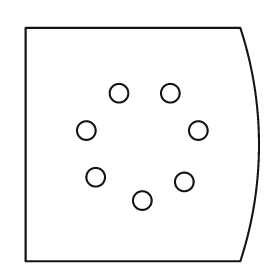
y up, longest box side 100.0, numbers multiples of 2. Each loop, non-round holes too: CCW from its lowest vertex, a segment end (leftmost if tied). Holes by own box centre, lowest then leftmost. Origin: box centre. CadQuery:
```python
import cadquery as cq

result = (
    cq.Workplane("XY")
    .moveTo(-50.0, -50.0)
    .lineTo(42.0, -50.0)
    .threePointArc((50.0, 0.0), (42.0, 50.0))
    .lineTo(-50.0, 50.0)
    .close()
    .moveTo(0.0, -24.0)
    .circle(4.0)
    .moveTo(18.0, -16.0)
    .circle(4.0)
    .moveTo(-20.0, -14.0)
    .circle(4.0)
    .moveTo(-24.0, 6.0)
    .circle(4.0)
    .moveTo(24.0, 6.0)
    .circle(4.0)
    .moveTo(-10.0, 22.0)
    .circle(4.0)
    .moveTo(12.0, 22.0)
    .circle(4.0)
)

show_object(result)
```